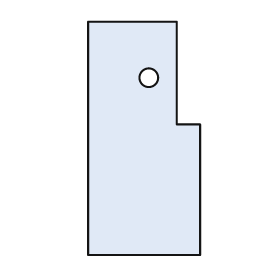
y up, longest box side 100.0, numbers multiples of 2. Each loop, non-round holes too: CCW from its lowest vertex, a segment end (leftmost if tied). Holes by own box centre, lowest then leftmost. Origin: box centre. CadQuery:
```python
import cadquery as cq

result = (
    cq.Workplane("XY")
    .moveTo(-24.0, -50.0)
    .lineTo(24.0, -50.0)
    .lineTo(24.0, 6.0)
    .lineTo(14.0, 6.0)
    .lineTo(14.0, 50.0)
    .lineTo(-24.0, 50.0)
    .close()
    .moveTo(2.0, 26.0)
    .circle(4.0)
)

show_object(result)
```